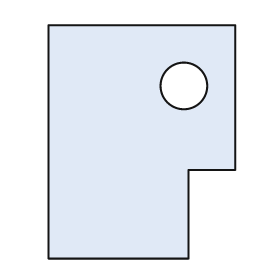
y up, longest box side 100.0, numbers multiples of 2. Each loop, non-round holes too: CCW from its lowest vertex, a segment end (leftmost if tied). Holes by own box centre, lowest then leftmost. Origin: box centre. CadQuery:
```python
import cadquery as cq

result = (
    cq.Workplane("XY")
    .moveTo(-40.0, -50.0)
    .lineTo(20.0, -50.0)
    .lineTo(20.0, -12.0)
    .lineTo(40.0, -12.0)
    .lineTo(40.0, 50.0)
    .lineTo(-40.0, 50.0)
    .close()
    .moveTo(18.0, 24.0)
    .circle(10.0)
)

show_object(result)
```